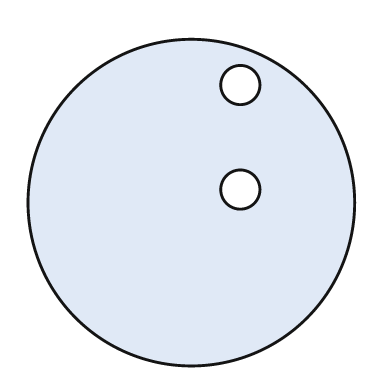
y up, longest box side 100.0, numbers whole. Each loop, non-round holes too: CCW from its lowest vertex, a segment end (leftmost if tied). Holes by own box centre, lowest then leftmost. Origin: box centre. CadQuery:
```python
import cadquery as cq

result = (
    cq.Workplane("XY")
    .moveTo(0.0, 0.0)
    .circle(50.0)
    .moveTo(15.0, 4.0)
    .circle(6.0)
    .moveTo(15.0, 36.0)
    .circle(6.0)
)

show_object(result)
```